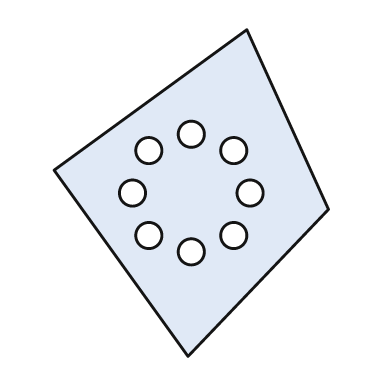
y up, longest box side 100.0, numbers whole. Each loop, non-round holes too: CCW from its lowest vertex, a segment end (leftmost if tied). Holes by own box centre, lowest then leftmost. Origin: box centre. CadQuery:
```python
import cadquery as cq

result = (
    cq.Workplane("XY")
    .moveTo(-1.0, -50.0)
    .lineTo(42.0, -5.0)
    .lineTo(17.0, 50.0)
    .lineTo(-42.0, 7.0)
    .close()
    .moveTo(0.0, -18.0)
    .circle(4.0)
    .moveTo(-13.0, -13.0)
    .circle(4.0)
    .moveTo(13.0, -13.0)
    .circle(4.0)
    .moveTo(-18.0, 0.0)
    .circle(4.0)
    .moveTo(18.0, 0.0)
    .circle(4.0)
    .moveTo(-13.0, 13.0)
    .circle(4.0)
    .moveTo(13.0, 13.0)
    .circle(4.0)
    .moveTo(0.0, 18.0)
    .circle(4.0)
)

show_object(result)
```